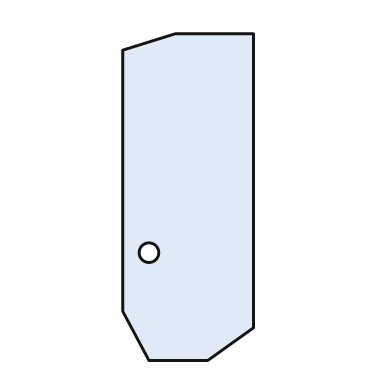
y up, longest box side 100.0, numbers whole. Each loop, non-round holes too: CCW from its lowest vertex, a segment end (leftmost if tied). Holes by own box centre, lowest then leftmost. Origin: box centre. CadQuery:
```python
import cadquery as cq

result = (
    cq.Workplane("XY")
    .moveTo(-12.0, -50.0)
    .lineTo(6.0, -50.0)
    .lineTo(20.0, -40.0)
    .lineTo(20.0, 50.0)
    .lineTo(-4.0, 50.0)
    .lineTo(-20.0, 45.0)
    .lineTo(-20.0, -35.0)
    .close()
    .moveTo(-12.0, -17.0)
    .circle(3.0)
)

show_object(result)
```